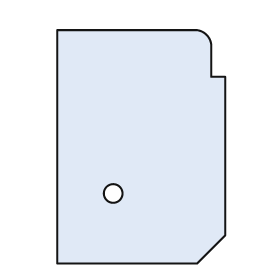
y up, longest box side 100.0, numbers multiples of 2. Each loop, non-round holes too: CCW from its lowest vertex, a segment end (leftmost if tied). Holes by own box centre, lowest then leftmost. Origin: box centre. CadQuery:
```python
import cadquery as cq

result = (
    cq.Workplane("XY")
    .moveTo(-36.0, -50.0)
    .lineTo(24.0, -50.0)
    .lineTo(36.0, -38.0)
    .lineTo(36.0, 30.0)
    .lineTo(30.0, 30.0)
    .lineTo(30.0, 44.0)
    .threePointArc((28.0, 48.0), (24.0, 50.0))
    .lineTo(-36.0, 50.0)
    .close()
    .moveTo(-12.0, -20.0)
    .circle(4.0)
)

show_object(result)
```